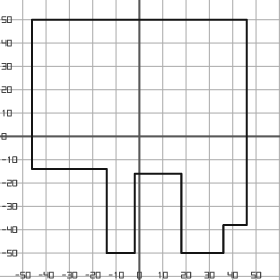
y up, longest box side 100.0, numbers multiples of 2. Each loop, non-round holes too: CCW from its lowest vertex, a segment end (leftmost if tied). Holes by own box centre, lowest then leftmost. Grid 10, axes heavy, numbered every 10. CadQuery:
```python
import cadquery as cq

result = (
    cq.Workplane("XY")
    .moveTo(-14.0, -50.0)
    .lineTo(-2.0, -50.0)
    .lineTo(-2.0, -16.0)
    .lineTo(18.0, -16.0)
    .lineTo(18.0, -50.0)
    .lineTo(36.0, -50.0)
    .lineTo(36.0, -38.0)
    .lineTo(46.0, -38.0)
    .lineTo(46.0, 50.0)
    .lineTo(-46.0, 50.0)
    .lineTo(-46.0, -14.0)
    .lineTo(-14.0, -14.0)
    .close()
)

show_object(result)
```